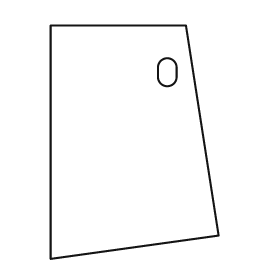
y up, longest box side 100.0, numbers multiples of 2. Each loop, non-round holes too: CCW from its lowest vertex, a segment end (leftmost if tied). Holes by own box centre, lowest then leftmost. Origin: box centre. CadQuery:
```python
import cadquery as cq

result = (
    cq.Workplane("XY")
    .moveTo(-36.0, -50.0)
    .lineTo(36.0, -40.0)
    .lineTo(22.0, 50.0)
    .lineTo(-36.0, 50.0)
    .close()
    .moveTo(10.0, 28.0)
    .threePointArc((14.0, 24.0), (18.0, 28.0))
    .lineTo(18.0, 32.0)
    .threePointArc((14.0, 36.0), (10.0, 32.0))
    .close()
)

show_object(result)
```